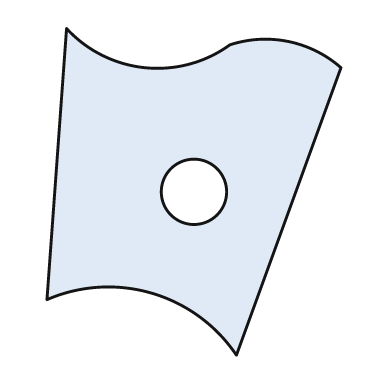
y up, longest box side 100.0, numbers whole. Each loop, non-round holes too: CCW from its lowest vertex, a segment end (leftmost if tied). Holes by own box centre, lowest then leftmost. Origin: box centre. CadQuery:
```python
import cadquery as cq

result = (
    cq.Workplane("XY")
    .moveTo(13.0, -50.0)
    .lineTo(45.0, 38.0)
    .threePointArc((29.0, 46.0), (11.0, 45.0))
    .threePointArc((-15.0, 38.0), (-39.0, 50.0))
    .lineTo(-45.0, -33.0)
    .threePointArc((-13.0, -31.0), (13.0, -50.0))
    .close()
    .moveTo(0.0, 0.0)
    .circle(10.0)
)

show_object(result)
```